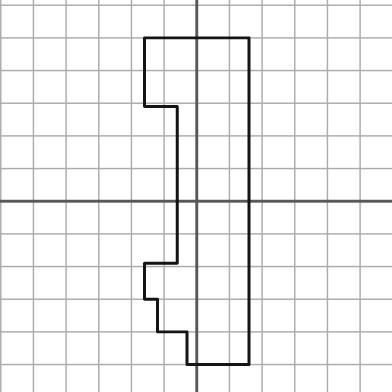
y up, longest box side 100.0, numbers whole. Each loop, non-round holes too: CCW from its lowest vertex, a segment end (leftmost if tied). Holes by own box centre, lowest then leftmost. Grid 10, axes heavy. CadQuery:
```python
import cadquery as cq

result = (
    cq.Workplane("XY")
    .moveTo(-3.0, -50.0)
    .lineTo(16.0, -50.0)
    .lineTo(16.0, 50.0)
    .lineTo(-16.0, 50.0)
    .lineTo(-16.0, 29.0)
    .lineTo(-6.0, 29.0)
    .lineTo(-6.0, -19.0)
    .lineTo(-16.0, -19.0)
    .lineTo(-16.0, -30.0)
    .lineTo(-12.0, -30.0)
    .lineTo(-12.0, -40.0)
    .lineTo(-3.0, -40.0)
    .close()
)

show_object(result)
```